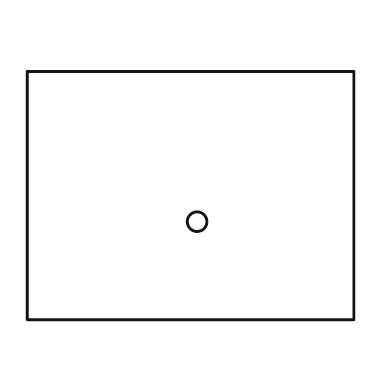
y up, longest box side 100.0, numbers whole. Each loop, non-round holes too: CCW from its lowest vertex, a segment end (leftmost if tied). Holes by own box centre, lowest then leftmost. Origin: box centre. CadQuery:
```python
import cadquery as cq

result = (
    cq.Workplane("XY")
    .moveTo(-50.0, -38.0)
    .lineTo(50.0, -38.0)
    .lineTo(50.0, 38.0)
    .lineTo(-50.0, 38.0)
    .close()
    .moveTo(2.0, -8.0)
    .circle(3.0)
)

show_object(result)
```